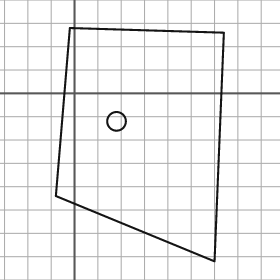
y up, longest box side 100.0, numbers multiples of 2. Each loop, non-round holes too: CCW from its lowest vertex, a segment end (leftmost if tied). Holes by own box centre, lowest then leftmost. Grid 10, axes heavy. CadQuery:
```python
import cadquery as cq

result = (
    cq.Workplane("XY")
    .moveTo(60.0, -72.0)
    .lineTo(64.0, 26.0)
    .lineTo(-2.0, 28.0)
    .lineTo(-8.0, -44.0)
    .close()
    .moveTo(18.0, -12.0)
    .circle(4.0)
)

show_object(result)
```